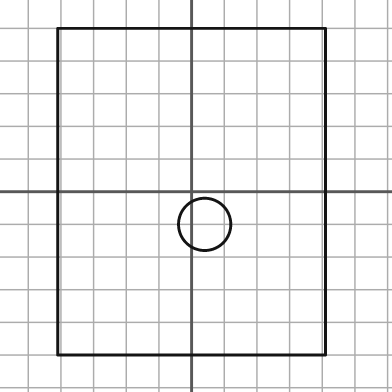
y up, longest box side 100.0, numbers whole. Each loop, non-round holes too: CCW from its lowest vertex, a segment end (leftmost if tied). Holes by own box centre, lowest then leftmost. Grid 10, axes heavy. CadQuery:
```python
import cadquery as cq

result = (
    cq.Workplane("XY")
    .moveTo(-41.0, -50.0)
    .lineTo(41.0, -50.0)
    .lineTo(41.0, 50.0)
    .lineTo(-41.0, 50.0)
    .close()
    .moveTo(4.0, -10.0)
    .circle(8.0)
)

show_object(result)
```